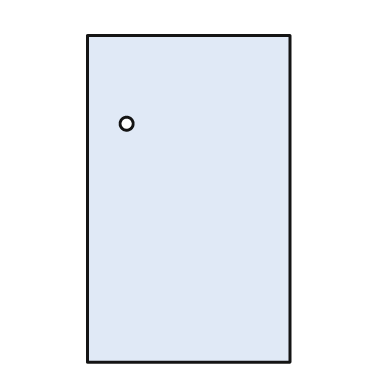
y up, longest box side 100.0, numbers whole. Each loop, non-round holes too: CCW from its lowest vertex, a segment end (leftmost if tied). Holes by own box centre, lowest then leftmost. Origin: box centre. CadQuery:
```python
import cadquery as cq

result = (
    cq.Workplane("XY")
    .moveTo(-31.0, -50.0)
    .lineTo(31.0, -50.0)
    .lineTo(31.0, 50.0)
    .lineTo(-31.0, 50.0)
    .close()
    .moveTo(-19.0, 23.0)
    .circle(2.0)
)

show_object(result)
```